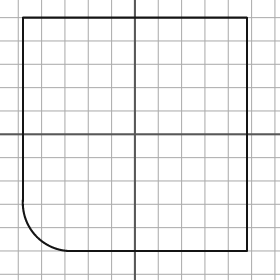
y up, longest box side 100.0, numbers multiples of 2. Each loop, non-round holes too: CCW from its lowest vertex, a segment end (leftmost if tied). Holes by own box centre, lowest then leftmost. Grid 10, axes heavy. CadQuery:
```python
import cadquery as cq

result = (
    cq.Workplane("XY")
    .moveTo(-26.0, -50.0)
    .lineTo(48.0, -50.0)
    .lineTo(48.0, 50.0)
    .lineTo(-48.0, 50.0)
    .lineTo(-48.0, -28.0)
    .threePointArc((-42.0, -44.0), (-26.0, -50.0))
    .close()
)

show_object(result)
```